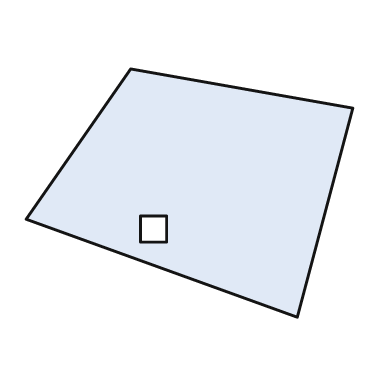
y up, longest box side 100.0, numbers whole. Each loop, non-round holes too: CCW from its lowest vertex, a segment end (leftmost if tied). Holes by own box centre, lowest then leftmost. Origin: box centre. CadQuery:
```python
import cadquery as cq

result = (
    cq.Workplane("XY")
    .moveTo(33.0, -38.0)
    .lineTo(50.0, 26.0)
    .lineTo(-18.0, 38.0)
    .lineTo(-50.0, -8.0)
    .close()
    .moveTo(-15.0, -15.0)
    .lineTo(-7.0, -15.0)
    .lineTo(-7.0, -7.0)
    .lineTo(-15.0, -7.0)
    .close()
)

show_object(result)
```